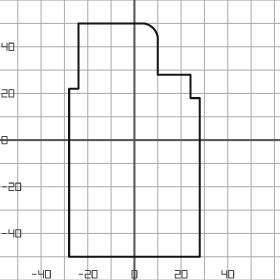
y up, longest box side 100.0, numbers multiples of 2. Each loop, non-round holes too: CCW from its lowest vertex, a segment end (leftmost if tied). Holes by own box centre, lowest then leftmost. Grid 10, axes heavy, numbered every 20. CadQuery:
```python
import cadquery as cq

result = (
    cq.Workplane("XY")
    .moveTo(-28.0, -50.0)
    .lineTo(28.0, -50.0)
    .lineTo(28.0, 18.0)
    .lineTo(24.0, 18.0)
    .lineTo(24.0, 28.0)
    .lineTo(10.0, 28.0)
    .lineTo(10.0, 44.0)
    .threePointArc((8.0, 48.0), (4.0, 50.0))
    .lineTo(-24.0, 50.0)
    .lineTo(-24.0, 22.0)
    .lineTo(-28.0, 22.0)
    .close()
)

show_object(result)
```